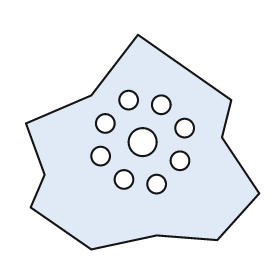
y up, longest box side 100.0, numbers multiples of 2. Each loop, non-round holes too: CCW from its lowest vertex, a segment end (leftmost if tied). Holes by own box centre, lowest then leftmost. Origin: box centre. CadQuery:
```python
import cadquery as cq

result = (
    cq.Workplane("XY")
    .moveTo(-22.0, -46.0)
    .lineTo(6.0, -40.0)
    .lineTo(32.0, -42.0)
    .lineTo(50.0, -22.0)
    .lineTo(34.0, 2.0)
    .lineTo(38.0, 18.0)
    .lineTo(-2.0, 46.0)
    .lineTo(-22.0, 20.0)
    .lineTo(-50.0, 8.0)
    .lineTo(-42.0, -14.0)
    .lineTo(-48.0, -28.0)
    .close()
    .moveTo(6.0, -18.0)
    .circle(4.0)
    .moveTo(-8.0, -16.0)
    .circle(4.0)
    .moveTo(16.0, -8.0)
    .circle(4.0)
    .moveTo(-18.0, -6.0)
    .circle(4.0)
    .moveTo(0.0, 0.0)
    .circle(6.0)
    .moveTo(18.0, 6.0)
    .circle(4.0)
    .moveTo(-16.0, 8.0)
    .circle(4.0)
    .moveTo(8.0, 16.0)
    .circle(4.0)
    .moveTo(-6.0, 18.0)
    .circle(4.0)
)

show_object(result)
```